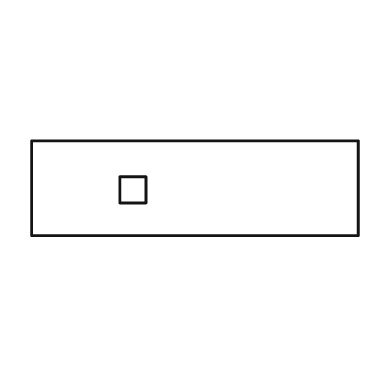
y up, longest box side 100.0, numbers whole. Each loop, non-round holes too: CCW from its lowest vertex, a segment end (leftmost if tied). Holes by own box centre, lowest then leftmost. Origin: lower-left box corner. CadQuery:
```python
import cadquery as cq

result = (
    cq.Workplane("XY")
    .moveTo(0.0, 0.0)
    .lineTo(100.0, 0.0)
    .lineTo(100.0, 29.0)
    .lineTo(0.0, 29.0)
    .close()
    .moveTo(27.0, 10.0)
    .lineTo(35.0, 10.0)
    .lineTo(35.0, 18.0)
    .lineTo(27.0, 18.0)
    .close()
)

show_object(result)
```